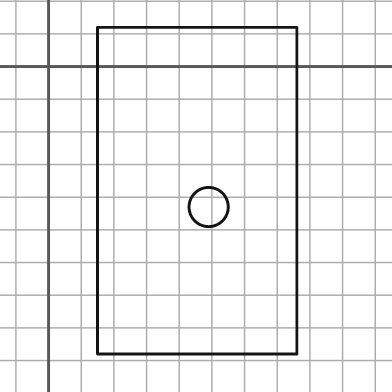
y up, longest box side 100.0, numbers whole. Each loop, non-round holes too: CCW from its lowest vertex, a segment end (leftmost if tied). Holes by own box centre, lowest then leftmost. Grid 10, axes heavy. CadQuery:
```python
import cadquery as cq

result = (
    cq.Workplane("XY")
    .moveTo(15.0, -88.0)
    .lineTo(76.0, -88.0)
    .lineTo(76.0, 12.0)
    .lineTo(15.0, 12.0)
    .close()
    .moveTo(49.0, -43.0)
    .circle(6.0)
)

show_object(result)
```